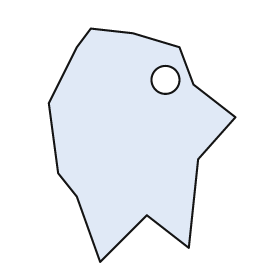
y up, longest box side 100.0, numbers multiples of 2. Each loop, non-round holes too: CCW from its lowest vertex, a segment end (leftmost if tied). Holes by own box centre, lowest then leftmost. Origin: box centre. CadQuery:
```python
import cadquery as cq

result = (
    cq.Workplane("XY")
    .moveTo(-18.0, -50.0)
    .lineTo(2.0, -30.0)
    .lineTo(20.0, -44.0)
    .lineTo(24.0, -6.0)
    .lineTo(40.0, 12.0)
    .lineTo(22.0, 26.0)
    .lineTo(16.0, 42.0)
    .lineTo(-4.0, 48.0)
    .lineTo(-22.0, 50.0)
    .lineTo(-28.0, 42.0)
    .lineTo(-40.0, 18.0)
    .lineTo(-36.0, -12.0)
    .lineTo(-28.0, -22.0)
    .close()
    .moveTo(10.0, 28.0)
    .circle(6.0)
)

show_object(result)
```